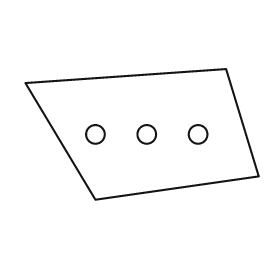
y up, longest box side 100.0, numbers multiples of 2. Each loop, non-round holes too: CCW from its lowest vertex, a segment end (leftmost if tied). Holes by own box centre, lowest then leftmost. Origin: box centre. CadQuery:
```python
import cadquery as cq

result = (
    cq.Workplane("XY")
    .moveTo(-20.0, -28.0)
    .lineTo(50.0, -18.0)
    .lineTo(36.0, 28.0)
    .lineTo(-50.0, 22.0)
    .close()
    .moveTo(-20.0, 0.0)
    .circle(4.0)
    .moveTo(2.0, 0.0)
    .circle(4.0)
    .moveTo(24.0, 0.0)
    .circle(4.0)
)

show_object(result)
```